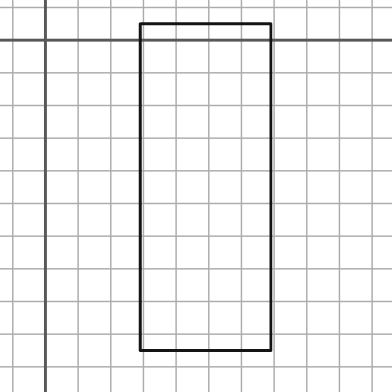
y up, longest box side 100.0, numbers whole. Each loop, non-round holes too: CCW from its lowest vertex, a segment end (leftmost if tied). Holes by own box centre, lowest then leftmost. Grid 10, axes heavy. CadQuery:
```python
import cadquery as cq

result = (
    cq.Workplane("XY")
    .moveTo(29.0, -95.0)
    .lineTo(69.0, -95.0)
    .lineTo(69.0, 5.0)
    .lineTo(29.0, 5.0)
    .close()
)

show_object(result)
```